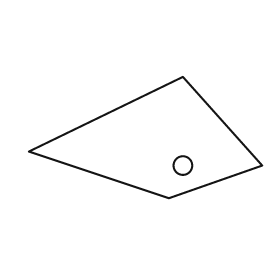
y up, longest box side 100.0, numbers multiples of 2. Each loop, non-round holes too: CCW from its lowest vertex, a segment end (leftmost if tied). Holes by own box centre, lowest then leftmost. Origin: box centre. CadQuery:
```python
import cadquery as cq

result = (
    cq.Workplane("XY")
    .moveTo(10.0, -26.0)
    .lineTo(50.0, -12.0)
    .lineTo(16.0, 26.0)
    .lineTo(-50.0, -6.0)
    .close()
    .moveTo(16.0, -12.0)
    .circle(4.0)
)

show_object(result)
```